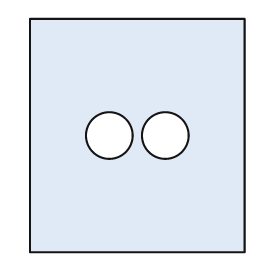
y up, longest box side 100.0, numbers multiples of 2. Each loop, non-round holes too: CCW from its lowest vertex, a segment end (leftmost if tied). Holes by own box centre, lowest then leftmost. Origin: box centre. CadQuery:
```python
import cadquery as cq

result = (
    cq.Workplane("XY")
    .moveTo(-46.0, -50.0)
    .lineTo(46.0, -50.0)
    .lineTo(46.0, 50.0)
    .lineTo(-46.0, 50.0)
    .close()
    .moveTo(-12.0, 0.0)
    .circle(10.0)
    .moveTo(12.0, 0.0)
    .circle(10.0)
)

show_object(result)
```